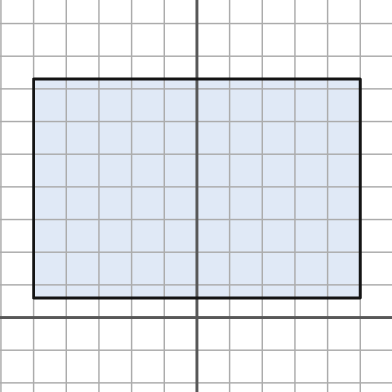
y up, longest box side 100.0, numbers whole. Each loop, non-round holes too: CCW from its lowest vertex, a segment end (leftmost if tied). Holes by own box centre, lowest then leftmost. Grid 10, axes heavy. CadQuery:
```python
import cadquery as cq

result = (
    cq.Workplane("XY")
    .moveTo(-50.0, 6.0)
    .lineTo(50.0, 6.0)
    .lineTo(50.0, 73.0)
    .lineTo(-50.0, 73.0)
    .close()
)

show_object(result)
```